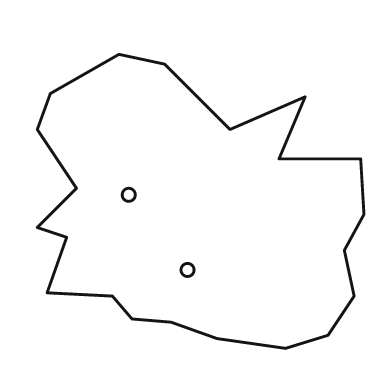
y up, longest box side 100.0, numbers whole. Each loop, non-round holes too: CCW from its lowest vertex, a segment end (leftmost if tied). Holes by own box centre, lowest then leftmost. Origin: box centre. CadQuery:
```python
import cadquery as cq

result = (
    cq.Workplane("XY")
    .moveTo(26.0, -45.0)
    .lineTo(39.0, -41.0)
    .lineTo(47.0, -29.0)
    .lineTo(44.0, -15.0)
    .lineTo(50.0, -4.0)
    .lineTo(49.0, 13.0)
    .lineTo(24.0, 13.0)
    .lineTo(32.0, 32.0)
    .lineTo(9.0, 22.0)
    .lineTo(-11.0, 42.0)
    .lineTo(-25.0, 45.0)
    .lineTo(-46.0, 33.0)
    .lineTo(-50.0, 22.0)
    .lineTo(-38.0, 4.0)
    .lineTo(-50.0, -8.0)
    .lineTo(-41.0, -11.0)
    .lineTo(-47.0, -28.0)
    .lineTo(-27.0, -29.0)
    .lineTo(-21.0, -36.0)
    .lineTo(-9.0, -37.0)
    .lineTo(5.0, -42.0)
    .close()
    .moveTo(-4.0, -21.0)
    .circle(2.0)
    .moveTo(-22.0, 2.0)
    .circle(2.0)
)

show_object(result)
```